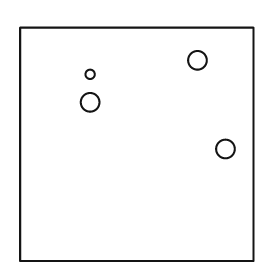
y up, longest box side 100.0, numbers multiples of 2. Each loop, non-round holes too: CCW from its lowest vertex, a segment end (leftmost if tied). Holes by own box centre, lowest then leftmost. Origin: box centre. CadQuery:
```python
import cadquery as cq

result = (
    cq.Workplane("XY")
    .moveTo(-50.0, -50.0)
    .lineTo(50.0, -50.0)
    .lineTo(50.0, 50.0)
    .lineTo(-50.0, 50.0)
    .close()
    .moveTo(38.0, -2.0)
    .circle(4.0)
    .moveTo(-20.0, 18.0)
    .circle(4.0)
    .moveTo(-20.0, 30.0)
    .circle(2.0)
    .moveTo(26.0, 36.0)
    .circle(4.0)
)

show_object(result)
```